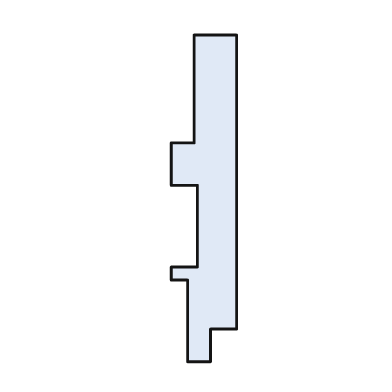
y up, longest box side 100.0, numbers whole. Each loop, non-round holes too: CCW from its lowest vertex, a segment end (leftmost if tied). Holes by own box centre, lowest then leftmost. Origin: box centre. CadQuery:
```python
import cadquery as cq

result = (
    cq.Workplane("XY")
    .moveTo(-5.0, -50.0)
    .lineTo(2.0, -50.0)
    .lineTo(2.0, -40.0)
    .lineTo(10.0, -40.0)
    .lineTo(10.0, 50.0)
    .lineTo(-3.0, 50.0)
    .lineTo(-3.0, 17.0)
    .lineTo(-10.0, 17.0)
    .lineTo(-10.0, 4.0)
    .lineTo(-2.0, 4.0)
    .lineTo(-2.0, -21.0)
    .lineTo(-10.0, -21.0)
    .lineTo(-10.0, -25.0)
    .lineTo(-5.0, -25.0)
    .close()
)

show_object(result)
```